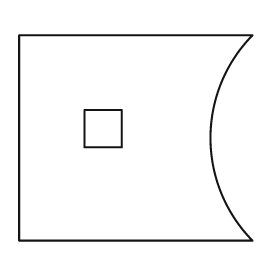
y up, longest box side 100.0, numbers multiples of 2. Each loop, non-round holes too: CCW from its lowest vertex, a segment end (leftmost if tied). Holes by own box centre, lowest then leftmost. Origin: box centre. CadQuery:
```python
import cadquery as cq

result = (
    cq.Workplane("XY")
    .moveTo(-50.0, -44.0)
    .lineTo(50.0, -44.0)
    .threePointArc((32.0, 0.0), (50.0, 44.0))
    .lineTo(-50.0, 44.0)
    .close()
    .moveTo(-22.0, -4.0)
    .lineTo(-6.0, -4.0)
    .lineTo(-6.0, 12.0)
    .lineTo(-22.0, 12.0)
    .close()
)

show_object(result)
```